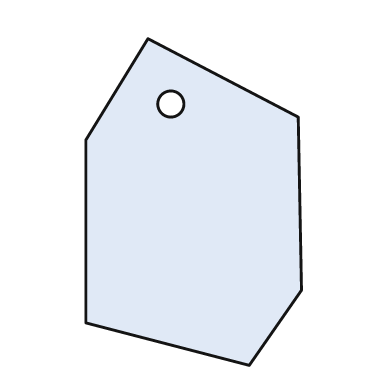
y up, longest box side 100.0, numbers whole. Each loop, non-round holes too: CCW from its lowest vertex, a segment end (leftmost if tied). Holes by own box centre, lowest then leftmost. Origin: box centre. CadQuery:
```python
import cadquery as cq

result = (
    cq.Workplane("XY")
    .moveTo(17.0, -50.0)
    .lineTo(33.0, -27.0)
    .lineTo(32.0, 26.0)
    .lineTo(-14.0, 50.0)
    .lineTo(-33.0, 19.0)
    .lineTo(-33.0, -37.0)
    .close()
    .moveTo(-7.0, 30.0)
    .circle(4.0)
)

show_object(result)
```